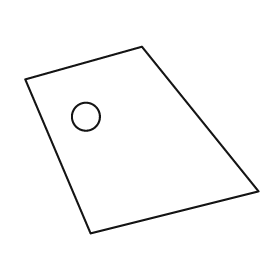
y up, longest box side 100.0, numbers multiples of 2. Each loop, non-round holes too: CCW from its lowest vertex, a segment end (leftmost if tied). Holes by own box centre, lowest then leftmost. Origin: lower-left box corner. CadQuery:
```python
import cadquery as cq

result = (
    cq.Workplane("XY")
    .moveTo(28.0, 0.0)
    .lineTo(100.0, 18.0)
    .lineTo(50.0, 80.0)
    .lineTo(0.0, 66.0)
    .close()
    .moveTo(26.0, 50.0)
    .circle(6.0)
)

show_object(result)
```